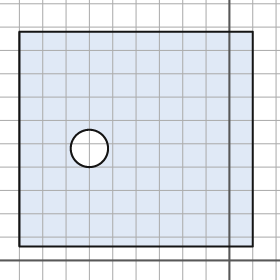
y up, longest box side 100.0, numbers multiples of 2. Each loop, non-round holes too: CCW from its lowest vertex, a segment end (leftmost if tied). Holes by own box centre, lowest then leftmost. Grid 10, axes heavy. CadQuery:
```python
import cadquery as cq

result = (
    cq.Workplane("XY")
    .moveTo(-90.0, 6.0)
    .lineTo(10.0, 6.0)
    .lineTo(10.0, 98.0)
    .lineTo(-90.0, 98.0)
    .close()
    .moveTo(-60.0, 48.0)
    .circle(8.0)
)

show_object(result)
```